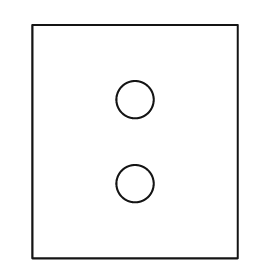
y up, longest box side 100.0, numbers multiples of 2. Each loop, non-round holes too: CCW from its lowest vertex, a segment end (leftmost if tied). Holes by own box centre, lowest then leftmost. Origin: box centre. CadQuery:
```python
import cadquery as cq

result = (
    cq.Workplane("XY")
    .moveTo(-44.0, -50.0)
    .lineTo(44.0, -50.0)
    .lineTo(44.0, 50.0)
    .lineTo(-44.0, 50.0)
    .close()
    .moveTo(0.0, -18.0)
    .circle(8.0)
    .moveTo(0.0, 18.0)
    .circle(8.0)
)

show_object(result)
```